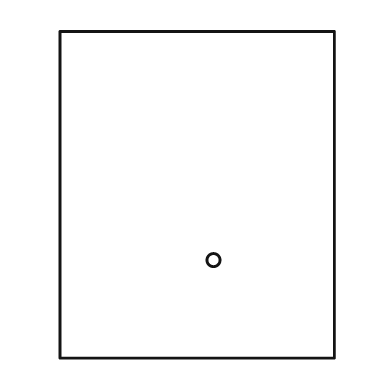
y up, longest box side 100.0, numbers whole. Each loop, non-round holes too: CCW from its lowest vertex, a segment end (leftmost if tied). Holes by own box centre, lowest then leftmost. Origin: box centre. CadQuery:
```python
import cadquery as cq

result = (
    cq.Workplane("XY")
    .moveTo(-42.0, -50.0)
    .lineTo(42.0, -50.0)
    .lineTo(42.0, 50.0)
    .lineTo(-42.0, 50.0)
    .close()
    .moveTo(5.0, -20.0)
    .circle(2.0)
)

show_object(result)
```